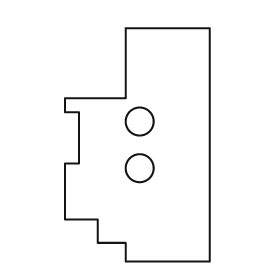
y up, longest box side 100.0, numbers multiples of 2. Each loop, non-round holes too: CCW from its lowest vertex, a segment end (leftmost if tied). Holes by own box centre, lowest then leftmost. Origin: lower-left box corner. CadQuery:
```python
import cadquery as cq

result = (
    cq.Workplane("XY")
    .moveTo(26.0, 0.0)
    .lineTo(62.0, 0.0)
    .lineTo(62.0, 100.0)
    .lineTo(26.0, 100.0)
    .lineTo(26.0, 70.0)
    .lineTo(0.0, 70.0)
    .lineTo(0.0, 64.0)
    .lineTo(6.0, 64.0)
    .lineTo(6.0, 42.0)
    .lineTo(0.0, 42.0)
    .lineTo(0.0, 18.0)
    .lineTo(14.0, 18.0)
    .lineTo(14.0, 8.0)
    .lineTo(26.0, 8.0)
    .close()
    .moveTo(32.0, 40.0)
    .circle(6.0)
    .moveTo(32.0, 60.0)
    .circle(6.0)
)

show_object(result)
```